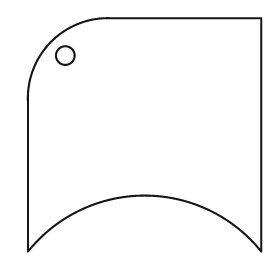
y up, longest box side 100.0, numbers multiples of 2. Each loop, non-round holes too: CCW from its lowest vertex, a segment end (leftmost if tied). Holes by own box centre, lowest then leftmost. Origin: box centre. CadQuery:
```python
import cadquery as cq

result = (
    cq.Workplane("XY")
    .moveTo(-50.0, -50.0)
    .threePointArc((0.0, -26.0), (50.0, -50.0))
    .lineTo(50.0, 50.0)
    .lineTo(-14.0, 50.0)
    .threePointArc((-40.0, 40.0), (-50.0, 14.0))
    .close()
    .moveTo(-34.0, 34.0)
    .circle(4.0)
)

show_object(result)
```